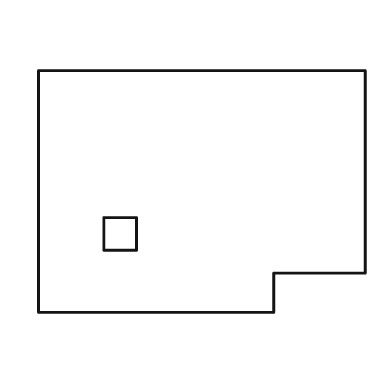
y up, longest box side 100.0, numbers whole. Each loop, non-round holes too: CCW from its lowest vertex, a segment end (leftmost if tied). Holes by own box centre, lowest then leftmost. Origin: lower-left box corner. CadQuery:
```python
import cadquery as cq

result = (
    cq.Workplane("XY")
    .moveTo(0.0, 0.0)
    .lineTo(72.0, 0.0)
    .lineTo(72.0, 12.0)
    .lineTo(100.0, 12.0)
    .lineTo(100.0, 74.0)
    .lineTo(0.0, 74.0)
    .close()
    .moveTo(20.0, 19.0)
    .lineTo(30.0, 19.0)
    .lineTo(30.0, 29.0)
    .lineTo(20.0, 29.0)
    .close()
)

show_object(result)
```